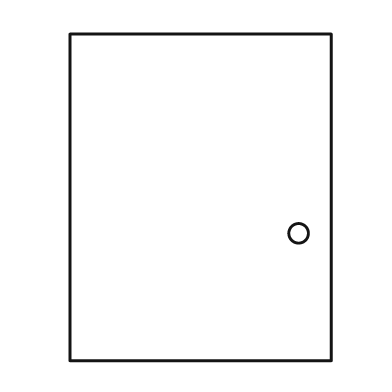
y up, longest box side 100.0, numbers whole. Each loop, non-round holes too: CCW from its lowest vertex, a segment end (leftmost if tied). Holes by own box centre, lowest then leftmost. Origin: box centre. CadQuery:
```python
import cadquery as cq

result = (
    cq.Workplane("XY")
    .moveTo(-40.0, -50.0)
    .lineTo(40.0, -50.0)
    .lineTo(40.0, 50.0)
    .lineTo(-40.0, 50.0)
    .close()
    .moveTo(30.0, -11.0)
    .circle(3.0)
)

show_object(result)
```